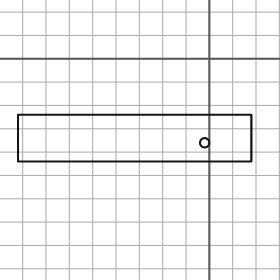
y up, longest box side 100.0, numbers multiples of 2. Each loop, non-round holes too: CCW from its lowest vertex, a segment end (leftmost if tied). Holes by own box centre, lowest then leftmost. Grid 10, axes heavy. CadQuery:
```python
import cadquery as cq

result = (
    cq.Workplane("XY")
    .moveTo(-82.0, -44.0)
    .lineTo(18.0, -44.0)
    .lineTo(18.0, -24.0)
    .lineTo(-82.0, -24.0)
    .close()
    .moveTo(-2.0, -36.0)
    .circle(2.0)
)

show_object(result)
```